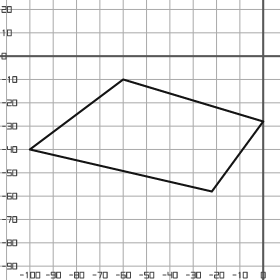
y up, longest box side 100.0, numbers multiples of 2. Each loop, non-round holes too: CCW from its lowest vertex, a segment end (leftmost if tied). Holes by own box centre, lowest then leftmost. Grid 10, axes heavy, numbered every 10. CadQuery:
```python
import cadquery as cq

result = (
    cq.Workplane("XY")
    .moveTo(-22.0, -58.0)
    .lineTo(0.0, -28.0)
    .lineTo(-60.0, -10.0)
    .lineTo(-100.0, -40.0)
    .close()
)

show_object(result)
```